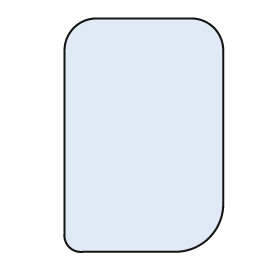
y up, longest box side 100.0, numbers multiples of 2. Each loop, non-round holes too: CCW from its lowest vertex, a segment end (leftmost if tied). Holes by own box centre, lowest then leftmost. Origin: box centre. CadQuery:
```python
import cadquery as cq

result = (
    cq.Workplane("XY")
    .moveTo(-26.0, -50.0)
    .lineTo(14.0, -50.0)
    .threePointArc((28.0, -44.0), (34.0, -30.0))
    .lineTo(34.0, 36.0)
    .threePointArc((30.0, 46.0), (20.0, 50.0))
    .lineTo(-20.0, 50.0)
    .threePointArc((-30.0, 46.0), (-34.0, 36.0))
    .lineTo(-34.0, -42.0)
    .threePointArc((-32.0, -48.0), (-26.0, -50.0))
    .close()
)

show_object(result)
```